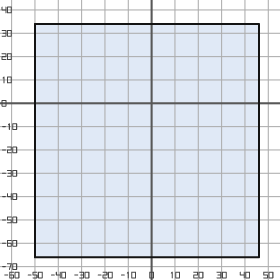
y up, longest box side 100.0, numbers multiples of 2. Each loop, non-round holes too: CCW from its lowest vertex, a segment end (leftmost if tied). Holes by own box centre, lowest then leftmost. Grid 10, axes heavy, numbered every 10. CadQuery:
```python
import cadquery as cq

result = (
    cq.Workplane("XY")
    .moveTo(-50.0, -66.0)
    .lineTo(46.0, -66.0)
    .lineTo(46.0, 34.0)
    .lineTo(-50.0, 34.0)
    .close()
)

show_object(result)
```